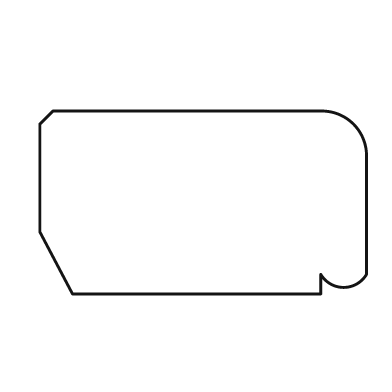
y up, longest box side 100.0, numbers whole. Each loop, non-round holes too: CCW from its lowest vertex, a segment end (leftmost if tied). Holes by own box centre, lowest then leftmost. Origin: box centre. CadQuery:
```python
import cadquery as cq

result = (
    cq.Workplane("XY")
    .moveTo(-40.0, -28.0)
    .lineTo(36.0, -28.0)
    .lineTo(36.0, -22.0)
    .threePointArc((43.0, -26.0), (50.0, -22.0))
    .lineTo(50.0, 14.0)
    .threePointArc((46.0, 24.0), (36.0, 28.0))
    .lineTo(-46.0, 28.0)
    .lineTo(-50.0, 24.0)
    .lineTo(-50.0, -9.0)
    .close()
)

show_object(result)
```